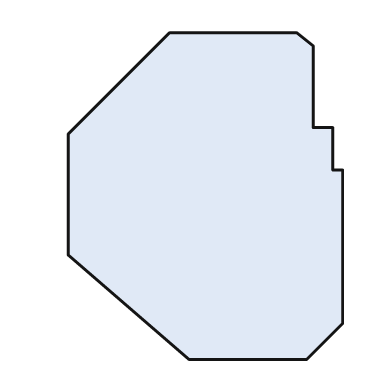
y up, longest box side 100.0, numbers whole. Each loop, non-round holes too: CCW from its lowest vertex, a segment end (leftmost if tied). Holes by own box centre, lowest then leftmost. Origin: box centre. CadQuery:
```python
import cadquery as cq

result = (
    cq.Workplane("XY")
    .moveTo(-5.0, -50.0)
    .lineTo(31.0, -50.0)
    .lineTo(42.0, -39.0)
    .lineTo(42.0, 8.0)
    .lineTo(39.0, 8.0)
    .lineTo(39.0, 21.0)
    .lineTo(33.0, 21.0)
    .lineTo(33.0, 46.0)
    .lineTo(28.0, 50.0)
    .lineTo(-11.0, 50.0)
    .lineTo(-42.0, 19.0)
    .lineTo(-42.0, -18.0)
    .close()
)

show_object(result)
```